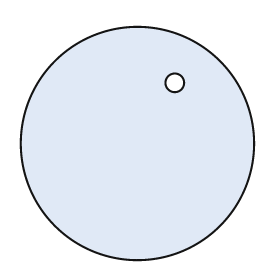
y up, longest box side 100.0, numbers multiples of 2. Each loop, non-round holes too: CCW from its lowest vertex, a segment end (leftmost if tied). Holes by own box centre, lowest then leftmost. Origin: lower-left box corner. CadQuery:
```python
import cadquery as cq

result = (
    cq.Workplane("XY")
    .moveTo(50.0, 50.0)
    .circle(50.0)
    .moveTo(66.0, 76.0)
    .circle(4.0)
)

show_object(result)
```